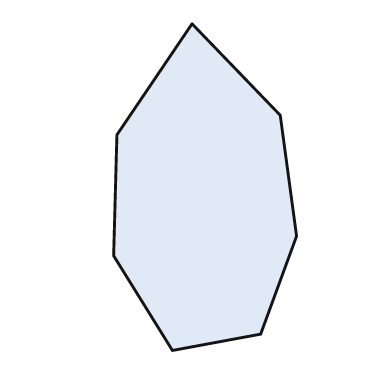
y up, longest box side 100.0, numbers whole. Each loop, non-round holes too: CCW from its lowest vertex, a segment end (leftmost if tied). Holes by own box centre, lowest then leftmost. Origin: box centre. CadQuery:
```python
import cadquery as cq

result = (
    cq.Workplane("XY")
    .moveTo(-10.0, -50.0)
    .lineTo(17.0, -45.0)
    .lineTo(28.0, -15.0)
    .lineTo(23.0, 22.0)
    .lineTo(-4.0, 50.0)
    .lineTo(-27.0, 16.0)
    .lineTo(-28.0, -21.0)
    .close()
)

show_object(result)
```